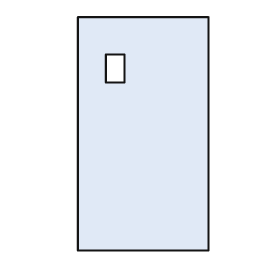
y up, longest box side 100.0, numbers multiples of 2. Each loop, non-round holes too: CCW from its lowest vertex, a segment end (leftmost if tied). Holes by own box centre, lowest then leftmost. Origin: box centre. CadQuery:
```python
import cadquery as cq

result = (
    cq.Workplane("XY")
    .moveTo(-28.0, -50.0)
    .lineTo(28.0, -50.0)
    .lineTo(28.0, 50.0)
    .lineTo(-28.0, 50.0)
    .close()
    .moveTo(-16.0, 22.0)
    .lineTo(-8.0, 22.0)
    .lineTo(-8.0, 34.0)
    .lineTo(-16.0, 34.0)
    .close()
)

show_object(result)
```